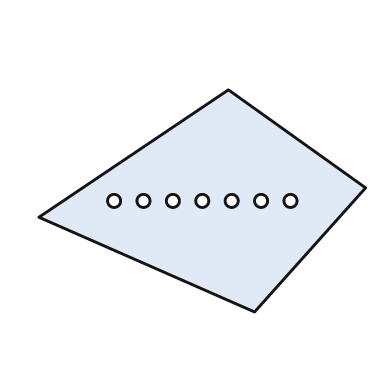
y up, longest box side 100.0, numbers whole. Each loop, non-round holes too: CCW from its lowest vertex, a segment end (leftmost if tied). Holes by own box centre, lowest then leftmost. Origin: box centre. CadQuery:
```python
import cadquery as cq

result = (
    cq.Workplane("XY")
    .moveTo(16.0, -34.0)
    .lineTo(50.0, 4.0)
    .lineTo(8.0, 34.0)
    .lineTo(-50.0, -5.0)
    .close()
    .moveTo(-27.0, 0.0)
    .circle(2.0)
    .moveTo(-18.0, 0.0)
    .circle(2.0)
    .moveTo(-9.0, 0.0)
    .circle(2.0)
    .moveTo(0.0, 0.0)
    .circle(2.0)
    .moveTo(9.0, 0.0)
    .circle(2.0)
    .moveTo(18.0, 0.0)
    .circle(2.0)
    .moveTo(27.0, 0.0)
    .circle(2.0)
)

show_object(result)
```